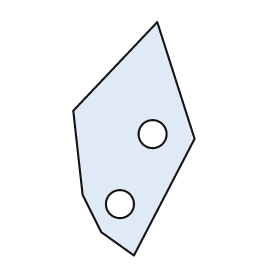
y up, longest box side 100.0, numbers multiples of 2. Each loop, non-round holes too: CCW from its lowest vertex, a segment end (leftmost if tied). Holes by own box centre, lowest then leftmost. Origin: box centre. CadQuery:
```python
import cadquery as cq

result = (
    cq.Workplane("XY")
    .moveTo(0.0, -50.0)
    .lineTo(26.0, 0.0)
    .lineTo(10.0, 50.0)
    .lineTo(-26.0, 12.0)
    .lineTo(-22.0, -24.0)
    .lineTo(-14.0, -40.0)
    .close()
    .moveTo(-6.0, -28.0)
    .circle(6.0)
    .moveTo(8.0, 2.0)
    .circle(6.0)
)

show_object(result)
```